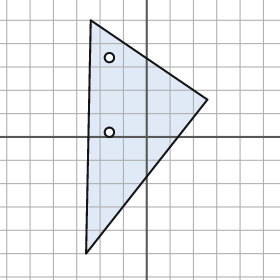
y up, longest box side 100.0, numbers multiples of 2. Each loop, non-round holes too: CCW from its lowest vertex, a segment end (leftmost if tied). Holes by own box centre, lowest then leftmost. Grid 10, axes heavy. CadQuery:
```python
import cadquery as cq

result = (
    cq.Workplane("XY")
    .moveTo(-26.0, -50.0)
    .lineTo(26.0, 16.0)
    .lineTo(-24.0, 50.0)
    .close()
    .moveTo(-16.0, 2.0)
    .circle(2.0)
    .moveTo(-16.0, 34.0)
    .circle(2.0)
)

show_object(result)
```